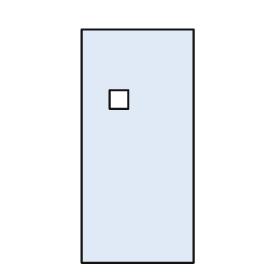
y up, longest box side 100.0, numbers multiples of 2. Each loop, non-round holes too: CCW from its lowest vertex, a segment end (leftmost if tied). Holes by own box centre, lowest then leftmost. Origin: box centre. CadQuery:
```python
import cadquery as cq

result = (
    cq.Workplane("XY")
    .moveTo(-24.0, -50.0)
    .lineTo(24.0, -50.0)
    .lineTo(24.0, 50.0)
    .lineTo(-24.0, 50.0)
    .close()
    .moveTo(-12.0, 16.0)
    .lineTo(-4.0, 16.0)
    .lineTo(-4.0, 24.0)
    .lineTo(-12.0, 24.0)
    .close()
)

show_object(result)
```